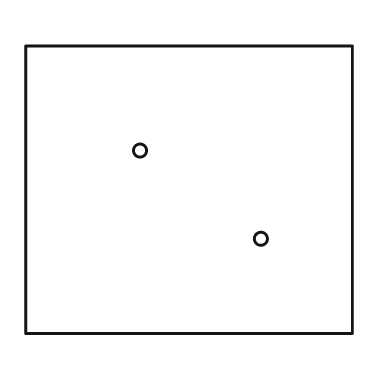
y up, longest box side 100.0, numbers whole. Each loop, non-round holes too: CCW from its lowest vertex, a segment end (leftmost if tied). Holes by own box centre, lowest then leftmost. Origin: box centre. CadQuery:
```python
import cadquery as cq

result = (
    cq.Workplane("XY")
    .moveTo(-50.0, -44.0)
    .lineTo(50.0, -44.0)
    .lineTo(50.0, 44.0)
    .lineTo(-50.0, 44.0)
    .close()
    .moveTo(22.0, -15.0)
    .circle(2.0)
    .moveTo(-15.0, 12.0)
    .circle(2.0)
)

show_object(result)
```